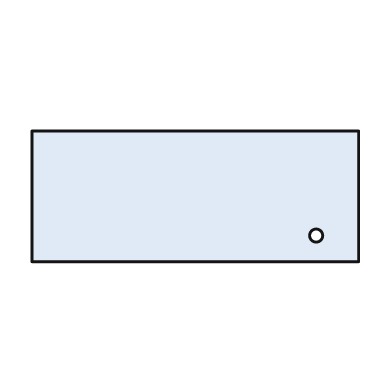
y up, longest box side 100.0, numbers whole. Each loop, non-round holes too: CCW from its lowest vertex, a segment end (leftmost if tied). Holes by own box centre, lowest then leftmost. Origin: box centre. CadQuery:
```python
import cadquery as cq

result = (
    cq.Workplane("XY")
    .moveTo(-50.0, -20.0)
    .lineTo(50.0, -20.0)
    .lineTo(50.0, 20.0)
    .lineTo(-50.0, 20.0)
    .close()
    .moveTo(37.0, -12.0)
    .circle(2.0)
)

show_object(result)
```